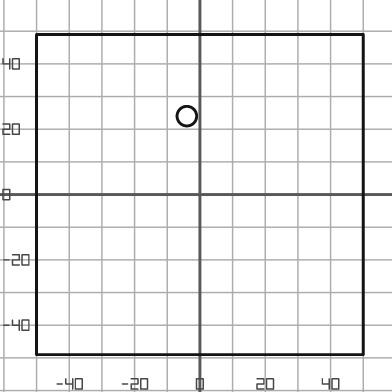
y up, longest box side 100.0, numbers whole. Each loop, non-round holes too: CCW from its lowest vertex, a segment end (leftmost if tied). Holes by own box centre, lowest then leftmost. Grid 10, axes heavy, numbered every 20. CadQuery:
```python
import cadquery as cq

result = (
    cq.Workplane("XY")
    .moveTo(-50.0, -49.0)
    .lineTo(50.0, -49.0)
    .lineTo(50.0, 49.0)
    .lineTo(-50.0, 49.0)
    .close()
    .moveTo(-4.0, 24.0)
    .circle(3.0)
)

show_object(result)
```